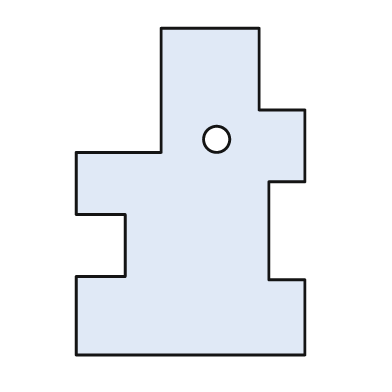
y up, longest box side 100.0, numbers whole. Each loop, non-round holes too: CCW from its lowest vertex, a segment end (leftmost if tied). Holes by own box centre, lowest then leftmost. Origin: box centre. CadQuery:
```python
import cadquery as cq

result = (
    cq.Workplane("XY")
    .moveTo(-35.0, -50.0)
    .lineTo(35.0, -50.0)
    .lineTo(35.0, -27.0)
    .lineTo(24.0, -27.0)
    .lineTo(24.0, 3.0)
    .lineTo(35.0, 3.0)
    .lineTo(35.0, 25.0)
    .lineTo(21.0, 25.0)
    .lineTo(21.0, 50.0)
    .lineTo(-9.0, 50.0)
    .lineTo(-9.0, 12.0)
    .lineTo(-35.0, 12.0)
    .lineTo(-35.0, -7.0)
    .lineTo(-20.0, -7.0)
    .lineTo(-20.0, -26.0)
    .lineTo(-35.0, -26.0)
    .close()
    .moveTo(8.0, 16.0)
    .circle(4.0)
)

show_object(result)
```